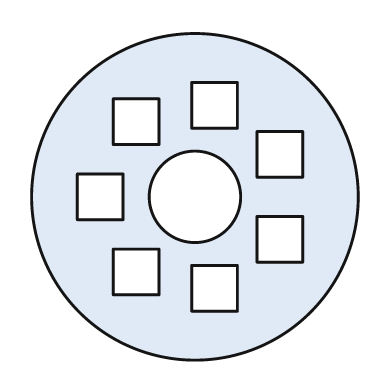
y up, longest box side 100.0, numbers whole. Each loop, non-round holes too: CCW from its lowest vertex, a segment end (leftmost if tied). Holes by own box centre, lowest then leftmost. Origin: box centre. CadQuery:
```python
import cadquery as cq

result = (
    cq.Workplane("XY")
    .moveTo(0.0, 0.0)
    .circle(50.0)
    .moveTo(-1.0, -35.0)
    .lineTo(13.0, -35.0)
    .lineTo(13.0, -21.0)
    .lineTo(-1.0, -21.0)
    .close()
    .moveTo(-25.0, -30.0)
    .lineTo(-11.0, -30.0)
    .lineTo(-11.0, -16.0)
    .lineTo(-25.0, -16.0)
    .close()
    .moveTo(19.0, -20.0)
    .lineTo(33.0, -20.0)
    .lineTo(33.0, -6.0)
    .lineTo(19.0, -6.0)
    .close()
    .moveTo(-36.0, -7.0)
    .lineTo(-22.0, -7.0)
    .lineTo(-22.0, 7.0)
    .lineTo(-36.0, 7.0)
    .close()
    .moveTo(0.0, 0.0)
    .circle(14.0)
    .moveTo(19.0, 6.0)
    .lineTo(33.0, 6.0)
    .lineTo(33.0, 20.0)
    .lineTo(19.0, 20.0)
    .close()
    .moveTo(-25.0, 16.0)
    .lineTo(-11.0, 16.0)
    .lineTo(-11.0, 30.0)
    .lineTo(-25.0, 30.0)
    .close()
    .moveTo(-1.0, 21.0)
    .lineTo(13.0, 21.0)
    .lineTo(13.0, 35.0)
    .lineTo(-1.0, 35.0)
    .close()
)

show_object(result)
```